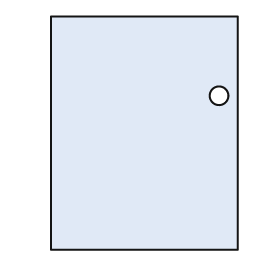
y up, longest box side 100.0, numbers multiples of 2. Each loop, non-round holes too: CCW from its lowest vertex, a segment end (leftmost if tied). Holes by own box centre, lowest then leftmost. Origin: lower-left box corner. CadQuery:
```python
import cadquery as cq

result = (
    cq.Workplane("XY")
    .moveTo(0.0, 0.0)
    .lineTo(80.0, 0.0)
    .lineTo(80.0, 100.0)
    .lineTo(0.0, 100.0)
    .close()
    .moveTo(72.0, 66.0)
    .circle(4.0)
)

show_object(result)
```